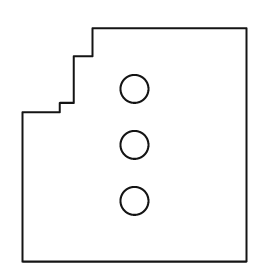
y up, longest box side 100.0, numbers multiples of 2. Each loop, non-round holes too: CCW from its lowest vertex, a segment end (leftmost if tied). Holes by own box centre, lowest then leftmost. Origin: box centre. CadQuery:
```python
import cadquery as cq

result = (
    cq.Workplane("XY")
    .moveTo(-48.0, -50.0)
    .lineTo(48.0, -50.0)
    .lineTo(48.0, 50.0)
    .lineTo(-18.0, 50.0)
    .lineTo(-18.0, 38.0)
    .lineTo(-26.0, 38.0)
    .lineTo(-26.0, 18.0)
    .lineTo(-32.0, 18.0)
    .lineTo(-32.0, 14.0)
    .lineTo(-48.0, 14.0)
    .close()
    .moveTo(0.0, -24.0)
    .circle(6.0)
    .moveTo(0.0, 0.0)
    .circle(6.0)
    .moveTo(0.0, 24.0)
    .circle(6.0)
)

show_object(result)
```